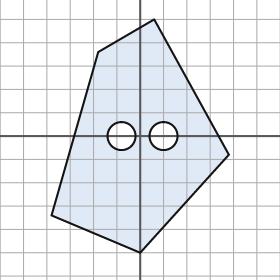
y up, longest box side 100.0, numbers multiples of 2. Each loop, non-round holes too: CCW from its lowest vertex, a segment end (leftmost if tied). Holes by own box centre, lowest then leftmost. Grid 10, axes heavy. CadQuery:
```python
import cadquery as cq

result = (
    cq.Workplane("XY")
    .moveTo(0.0, -50.0)
    .lineTo(38.0, -8.0)
    .lineTo(6.0, 50.0)
    .lineTo(-18.0, 36.0)
    .lineTo(-38.0, -34.0)
    .close()
    .moveTo(-8.0, 0.0)
    .circle(6.0)
    .moveTo(10.0, 0.0)
    .circle(6.0)
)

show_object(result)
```